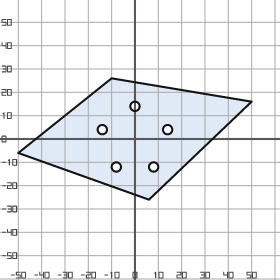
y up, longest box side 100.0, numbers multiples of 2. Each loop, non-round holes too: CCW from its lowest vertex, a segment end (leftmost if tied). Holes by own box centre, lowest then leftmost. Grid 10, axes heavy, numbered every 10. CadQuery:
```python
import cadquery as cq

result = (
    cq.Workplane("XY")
    .moveTo(6.0, -26.0)
    .lineTo(50.0, 16.0)
    .lineTo(-10.0, 26.0)
    .lineTo(-50.0, -6.0)
    .close()
    .moveTo(-8.0, -12.0)
    .circle(2.0)
    .moveTo(8.0, -12.0)
    .circle(2.0)
    .moveTo(-14.0, 4.0)
    .circle(2.0)
    .moveTo(14.0, 4.0)
    .circle(2.0)
    .moveTo(0.0, 14.0)
    .circle(2.0)
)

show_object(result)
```